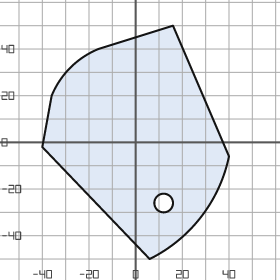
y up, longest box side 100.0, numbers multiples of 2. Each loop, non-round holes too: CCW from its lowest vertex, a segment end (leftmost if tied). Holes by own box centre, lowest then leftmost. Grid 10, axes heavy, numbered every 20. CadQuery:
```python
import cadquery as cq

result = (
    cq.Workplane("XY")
    .moveTo(6.0, -50.0)
    .threePointArc((28.0, -32.0), (40.0, -6.0))
    .lineTo(16.0, 50.0)
    .lineTo(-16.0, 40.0)
    .threePointArc((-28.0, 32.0), (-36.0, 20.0))
    .lineTo(-40.0, -2.0)
    .close()
    .moveTo(12.0, -26.0)
    .circle(4.0)
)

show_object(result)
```